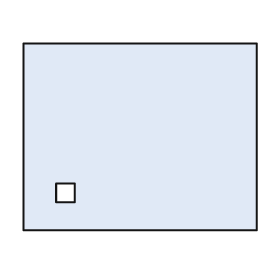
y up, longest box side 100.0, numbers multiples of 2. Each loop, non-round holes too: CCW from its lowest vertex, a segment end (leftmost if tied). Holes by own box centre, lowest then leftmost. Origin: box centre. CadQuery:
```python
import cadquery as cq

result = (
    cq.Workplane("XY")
    .moveTo(-50.0, -40.0)
    .lineTo(50.0, -40.0)
    .lineTo(50.0, 40.0)
    .lineTo(-50.0, 40.0)
    .close()
    .moveTo(-36.0, -28.0)
    .lineTo(-28.0, -28.0)
    .lineTo(-28.0, -20.0)
    .lineTo(-36.0, -20.0)
    .close()
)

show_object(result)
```